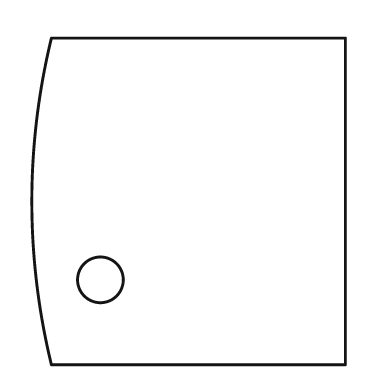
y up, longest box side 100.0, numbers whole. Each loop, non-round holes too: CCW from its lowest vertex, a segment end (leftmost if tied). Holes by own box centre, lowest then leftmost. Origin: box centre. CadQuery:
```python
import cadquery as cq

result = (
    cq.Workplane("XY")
    .moveTo(-42.0, -50.0)
    .lineTo(48.0, -50.0)
    .lineTo(48.0, 50.0)
    .lineTo(-42.0, 50.0)
    .threePointArc((-48.0, 0.0), (-42.0, -50.0))
    .close()
    .moveTo(-27.0, -24.0)
    .circle(7.0)
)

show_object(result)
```